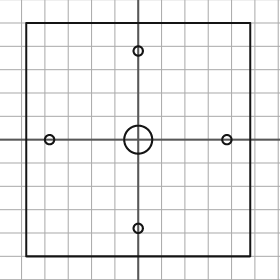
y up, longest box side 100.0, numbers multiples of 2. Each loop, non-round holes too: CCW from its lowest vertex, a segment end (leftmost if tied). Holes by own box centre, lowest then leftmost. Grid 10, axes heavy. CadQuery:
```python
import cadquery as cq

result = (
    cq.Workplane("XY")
    .moveTo(-48.0, -50.0)
    .lineTo(48.0, -50.0)
    .lineTo(48.0, 50.0)
    .lineTo(-48.0, 50.0)
    .close()
    .moveTo(0.0, -38.0)
    .circle(2.0)
    .moveTo(-38.0, 0.0)
    .circle(2.0)
    .moveTo(0.0, 0.0)
    .circle(6.0)
    .moveTo(38.0, 0.0)
    .circle(2.0)
    .moveTo(0.0, 38.0)
    .circle(2.0)
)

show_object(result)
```